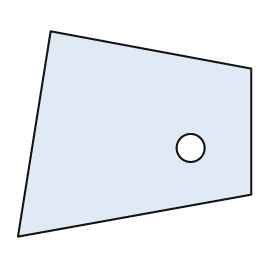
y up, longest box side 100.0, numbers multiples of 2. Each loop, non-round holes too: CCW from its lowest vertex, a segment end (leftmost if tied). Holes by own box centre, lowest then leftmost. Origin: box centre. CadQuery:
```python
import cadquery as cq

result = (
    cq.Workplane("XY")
    .moveTo(-50.0, -44.0)
    .lineTo(50.0, -26.0)
    .lineTo(50.0, 28.0)
    .lineTo(-36.0, 44.0)
    .close()
    .moveTo(24.0, -6.0)
    .circle(6.0)
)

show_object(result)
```